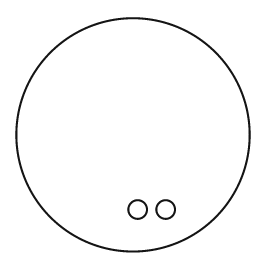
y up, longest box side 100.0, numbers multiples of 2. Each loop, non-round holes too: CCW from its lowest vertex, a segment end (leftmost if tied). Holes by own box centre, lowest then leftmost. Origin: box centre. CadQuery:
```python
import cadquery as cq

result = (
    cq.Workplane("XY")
    .moveTo(0.0, 0.0)
    .circle(50.0)
    .moveTo(2.0, -32.0)
    .circle(4.0)
    .moveTo(14.0, -32.0)
    .circle(4.0)
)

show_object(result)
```